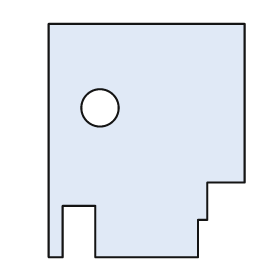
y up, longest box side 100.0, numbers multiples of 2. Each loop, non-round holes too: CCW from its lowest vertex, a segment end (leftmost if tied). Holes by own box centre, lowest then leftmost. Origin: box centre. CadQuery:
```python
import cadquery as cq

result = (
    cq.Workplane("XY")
    .moveTo(-42.0, -50.0)
    .lineTo(-36.0, -50.0)
    .lineTo(-36.0, -28.0)
    .lineTo(-22.0, -28.0)
    .lineTo(-22.0, -50.0)
    .lineTo(22.0, -50.0)
    .lineTo(22.0, -34.0)
    .lineTo(26.0, -34.0)
    .lineTo(26.0, -18.0)
    .lineTo(42.0, -18.0)
    .lineTo(42.0, 50.0)
    .lineTo(-42.0, 50.0)
    .close()
    .moveTo(-20.0, 14.0)
    .circle(8.0)
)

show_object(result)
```